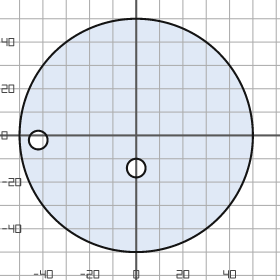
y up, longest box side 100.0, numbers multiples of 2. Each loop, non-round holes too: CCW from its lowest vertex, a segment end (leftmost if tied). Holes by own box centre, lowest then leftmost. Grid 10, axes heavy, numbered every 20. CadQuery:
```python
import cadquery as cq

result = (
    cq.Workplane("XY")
    .moveTo(0.0, 0.0)
    .circle(50.0)
    .moveTo(0.0, -14.0)
    .circle(4.0)
    .moveTo(-42.0, -2.0)
    .circle(4.0)
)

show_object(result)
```